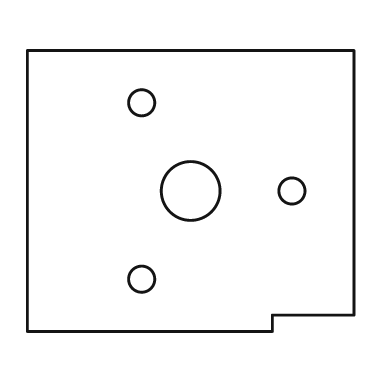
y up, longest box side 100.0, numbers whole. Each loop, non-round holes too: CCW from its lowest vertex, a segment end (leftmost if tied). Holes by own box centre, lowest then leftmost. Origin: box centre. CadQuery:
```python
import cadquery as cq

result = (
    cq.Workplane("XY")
    .moveTo(-50.0, -43.0)
    .lineTo(25.0, -43.0)
    .lineTo(25.0, -38.0)
    .lineTo(50.0, -38.0)
    .lineTo(50.0, 43.0)
    .lineTo(-50.0, 43.0)
    .close()
    .moveTo(-15.0, -27.0)
    .circle(4.0)
    .moveTo(0.0, 0.0)
    .circle(9.0)
    .moveTo(31.0, 0.0)
    .circle(4.0)
    .moveTo(-15.0, 27.0)
    .circle(4.0)
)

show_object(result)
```